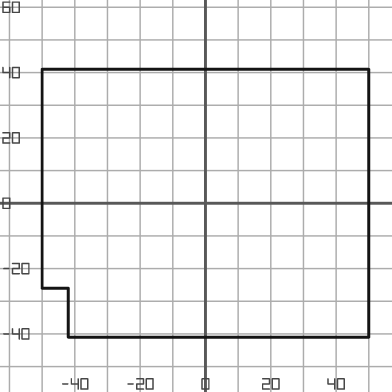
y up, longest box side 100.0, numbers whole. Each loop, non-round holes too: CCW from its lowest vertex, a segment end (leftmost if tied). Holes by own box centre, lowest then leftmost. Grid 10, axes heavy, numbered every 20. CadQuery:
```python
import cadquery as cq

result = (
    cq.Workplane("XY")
    .moveTo(-42.0, -41.0)
    .lineTo(50.0, -41.0)
    .lineTo(50.0, 41.0)
    .lineTo(-50.0, 41.0)
    .lineTo(-50.0, -26.0)
    .lineTo(-42.0, -26.0)
    .close()
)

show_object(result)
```